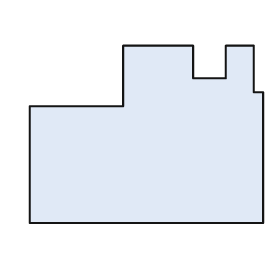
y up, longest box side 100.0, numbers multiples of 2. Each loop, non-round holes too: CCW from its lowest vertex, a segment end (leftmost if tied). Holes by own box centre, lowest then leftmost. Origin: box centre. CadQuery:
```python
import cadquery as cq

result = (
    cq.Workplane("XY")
    .moveTo(-50.0, -38.0)
    .lineTo(50.0, -38.0)
    .lineTo(50.0, 18.0)
    .lineTo(46.0, 18.0)
    .lineTo(46.0, 38.0)
    .lineTo(34.0, 38.0)
    .lineTo(34.0, 24.0)
    .lineTo(20.0, 24.0)
    .lineTo(20.0, 38.0)
    .lineTo(-10.0, 38.0)
    .lineTo(-10.0, 12.0)
    .lineTo(-50.0, 12.0)
    .close()
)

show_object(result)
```